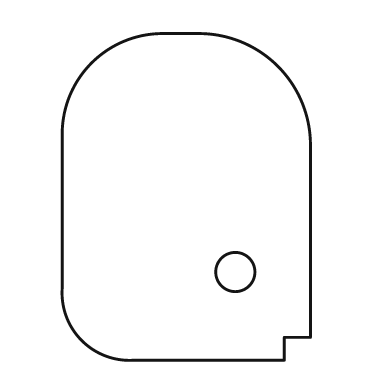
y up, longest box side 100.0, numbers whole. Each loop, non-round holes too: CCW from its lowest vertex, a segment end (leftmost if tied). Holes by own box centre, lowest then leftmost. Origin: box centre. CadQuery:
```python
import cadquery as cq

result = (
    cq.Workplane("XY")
    .moveTo(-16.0, -50.0)
    .lineTo(30.0, -50.0)
    .lineTo(30.0, -43.0)
    .lineTo(38.0, -43.0)
    .lineTo(38.0, 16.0)
    .threePointArc((28.0, 40.0), (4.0, 50.0))
    .lineTo(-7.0, 50.0)
    .threePointArc((-29.0, 41.0), (-38.0, 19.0))
    .lineTo(-38.0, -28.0)
    .threePointArc((-32.0, -44.0), (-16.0, -50.0))
    .close()
    .moveTo(15.0, -23.0)
    .circle(6.0)
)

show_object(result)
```